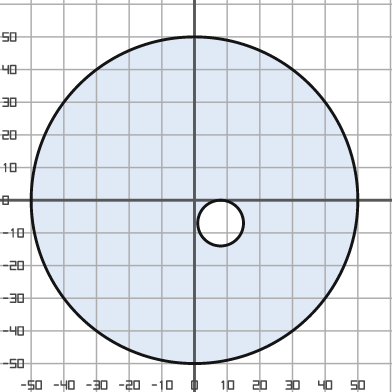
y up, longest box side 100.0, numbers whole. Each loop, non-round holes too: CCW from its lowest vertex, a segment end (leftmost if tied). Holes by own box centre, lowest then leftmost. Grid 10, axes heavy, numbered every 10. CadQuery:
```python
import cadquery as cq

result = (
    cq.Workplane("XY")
    .moveTo(0.0, 0.0)
    .circle(50.0)
    .moveTo(8.0, -7.0)
    .circle(7.0)
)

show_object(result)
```